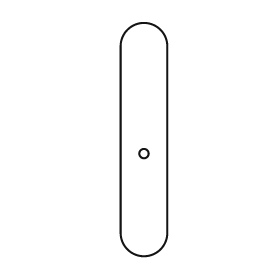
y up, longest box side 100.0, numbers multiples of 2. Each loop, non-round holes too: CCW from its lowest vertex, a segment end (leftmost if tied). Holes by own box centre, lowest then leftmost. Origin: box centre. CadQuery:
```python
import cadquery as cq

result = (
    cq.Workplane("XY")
    .moveTo(-10.0, -40.0)
    .threePointArc((0.0, -50.0), (10.0, -40.0))
    .lineTo(10.0, 40.0)
    .threePointArc((0.0, 50.0), (-10.0, 40.0))
    .close()
    .moveTo(0.0, -6.0)
    .circle(2.0)
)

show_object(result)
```